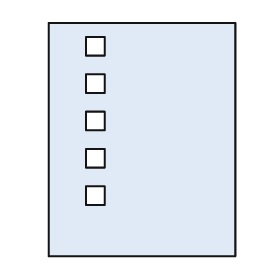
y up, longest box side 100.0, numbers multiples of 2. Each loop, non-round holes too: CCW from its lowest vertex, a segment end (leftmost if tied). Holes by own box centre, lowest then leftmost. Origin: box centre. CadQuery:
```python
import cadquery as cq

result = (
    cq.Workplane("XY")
    .moveTo(-40.0, -50.0)
    .lineTo(40.0, -50.0)
    .lineTo(40.0, 50.0)
    .lineTo(-40.0, 50.0)
    .close()
    .moveTo(-24.0, -28.0)
    .lineTo(-16.0, -28.0)
    .lineTo(-16.0, -20.0)
    .lineTo(-24.0, -20.0)
    .close()
    .moveTo(-24.0, -12.0)
    .lineTo(-16.0, -12.0)
    .lineTo(-16.0, -4.0)
    .lineTo(-24.0, -4.0)
    .close()
    .moveTo(-24.0, 4.0)
    .lineTo(-16.0, 4.0)
    .lineTo(-16.0, 12.0)
    .lineTo(-24.0, 12.0)
    .close()
    .moveTo(-24.0, 20.0)
    .lineTo(-16.0, 20.0)
    .lineTo(-16.0, 28.0)
    .lineTo(-24.0, 28.0)
    .close()
    .moveTo(-24.0, 36.0)
    .lineTo(-16.0, 36.0)
    .lineTo(-16.0, 44.0)
    .lineTo(-24.0, 44.0)
    .close()
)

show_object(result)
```